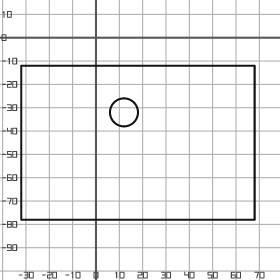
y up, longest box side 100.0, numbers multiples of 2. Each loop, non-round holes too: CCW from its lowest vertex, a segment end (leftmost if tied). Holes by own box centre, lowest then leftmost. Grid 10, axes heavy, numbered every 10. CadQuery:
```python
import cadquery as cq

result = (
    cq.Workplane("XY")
    .moveTo(-32.0, -78.0)
    .lineTo(68.0, -78.0)
    .lineTo(68.0, -12.0)
    .lineTo(-32.0, -12.0)
    .close()
    .moveTo(12.0, -32.0)
    .circle(6.0)
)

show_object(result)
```